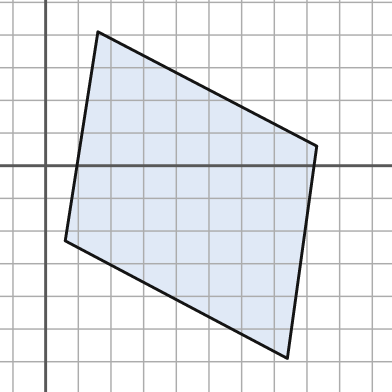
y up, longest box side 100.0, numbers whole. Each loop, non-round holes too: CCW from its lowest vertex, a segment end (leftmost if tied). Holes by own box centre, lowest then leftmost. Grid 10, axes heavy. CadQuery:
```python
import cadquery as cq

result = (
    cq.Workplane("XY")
    .moveTo(74.0, -59.0)
    .lineTo(83.0, 6.0)
    .lineTo(16.0, 41.0)
    .lineTo(6.0, -23.0)
    .close()
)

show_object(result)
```